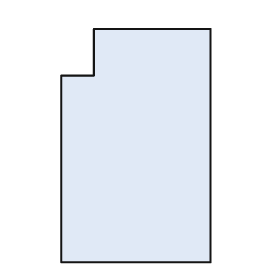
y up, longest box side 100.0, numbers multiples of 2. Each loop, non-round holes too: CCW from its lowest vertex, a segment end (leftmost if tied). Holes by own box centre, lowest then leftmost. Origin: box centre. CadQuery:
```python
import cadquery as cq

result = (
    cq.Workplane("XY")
    .moveTo(-32.0, -50.0)
    .lineTo(32.0, -50.0)
    .lineTo(32.0, 50.0)
    .lineTo(-18.0, 50.0)
    .lineTo(-18.0, 30.0)
    .lineTo(-32.0, 30.0)
    .close()
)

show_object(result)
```